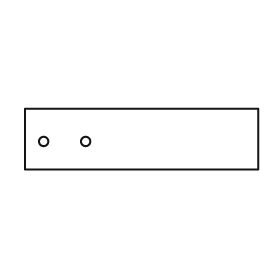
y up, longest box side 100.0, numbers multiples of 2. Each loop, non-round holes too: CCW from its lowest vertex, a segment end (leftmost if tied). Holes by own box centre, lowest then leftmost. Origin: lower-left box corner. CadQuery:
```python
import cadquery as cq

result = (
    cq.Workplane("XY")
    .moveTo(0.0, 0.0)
    .lineTo(100.0, 0.0)
    .lineTo(100.0, 26.0)
    .lineTo(0.0, 26.0)
    .close()
    .moveTo(8.0, 12.0)
    .circle(2.0)
    .moveTo(26.0, 12.0)
    .circle(2.0)
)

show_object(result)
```